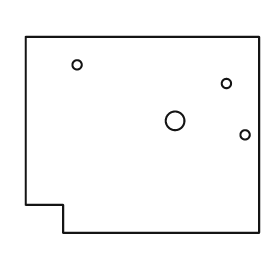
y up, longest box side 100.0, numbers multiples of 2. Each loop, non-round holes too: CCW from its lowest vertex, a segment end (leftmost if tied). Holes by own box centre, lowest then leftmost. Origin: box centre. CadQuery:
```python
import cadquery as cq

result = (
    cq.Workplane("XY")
    .moveTo(-34.0, -42.0)
    .lineTo(50.0, -42.0)
    .lineTo(50.0, 42.0)
    .lineTo(-50.0, 42.0)
    .lineTo(-50.0, -30.0)
    .lineTo(-34.0, -30.0)
    .close()
    .moveTo(44.0, 0.0)
    .circle(2.0)
    .moveTo(14.0, 6.0)
    .circle(4.0)
    .moveTo(36.0, 22.0)
    .circle(2.0)
    .moveTo(-28.0, 30.0)
    .circle(2.0)
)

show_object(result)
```